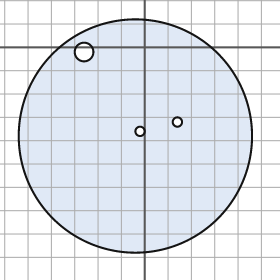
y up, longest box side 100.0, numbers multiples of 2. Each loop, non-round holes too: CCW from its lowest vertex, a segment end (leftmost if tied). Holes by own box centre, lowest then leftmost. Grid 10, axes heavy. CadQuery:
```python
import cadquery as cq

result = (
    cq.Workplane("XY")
    .moveTo(-4.0, -38.0)
    .circle(50.0)
    .moveTo(-2.0, -36.0)
    .circle(2.0)
    .moveTo(14.0, -32.0)
    .circle(2.0)
    .moveTo(-26.0, -2.0)
    .circle(4.0)
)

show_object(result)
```